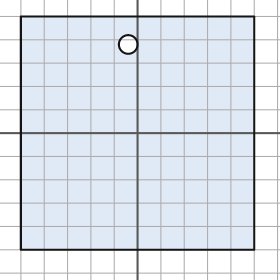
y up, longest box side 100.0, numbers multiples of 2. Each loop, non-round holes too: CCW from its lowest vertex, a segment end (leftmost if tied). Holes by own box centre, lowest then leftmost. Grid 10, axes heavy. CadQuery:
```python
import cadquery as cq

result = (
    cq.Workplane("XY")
    .moveTo(-50.0, -50.0)
    .lineTo(50.0, -50.0)
    .lineTo(50.0, 50.0)
    .lineTo(-50.0, 50.0)
    .close()
    .moveTo(-4.0, 38.0)
    .circle(4.0)
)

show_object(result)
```